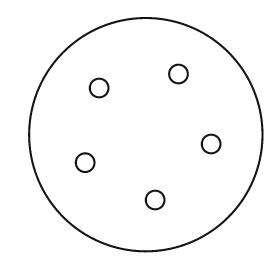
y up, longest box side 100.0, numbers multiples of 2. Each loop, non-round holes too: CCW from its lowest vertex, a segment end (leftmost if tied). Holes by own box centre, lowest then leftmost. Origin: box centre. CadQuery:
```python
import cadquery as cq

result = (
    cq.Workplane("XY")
    .moveTo(0.0, 0.0)
    .circle(50.0)
    .moveTo(4.0, -28.0)
    .circle(4.0)
    .moveTo(-26.0, -12.0)
    .circle(4.0)
    .moveTo(28.0, -4.0)
    .circle(4.0)
    .moveTo(-20.0, 20.0)
    .circle(4.0)
    .moveTo(14.0, 26.0)
    .circle(4.0)
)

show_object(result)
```